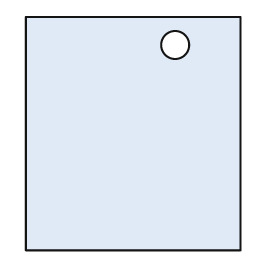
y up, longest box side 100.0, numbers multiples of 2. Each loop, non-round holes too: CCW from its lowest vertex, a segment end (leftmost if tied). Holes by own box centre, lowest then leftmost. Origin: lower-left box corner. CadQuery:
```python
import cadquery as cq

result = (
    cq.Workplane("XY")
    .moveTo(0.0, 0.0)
    .lineTo(92.0, 0.0)
    .lineTo(92.0, 100.0)
    .lineTo(0.0, 100.0)
    .close()
    .moveTo(64.0, 88.0)
    .circle(6.0)
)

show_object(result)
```